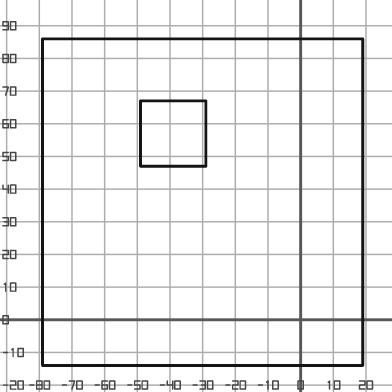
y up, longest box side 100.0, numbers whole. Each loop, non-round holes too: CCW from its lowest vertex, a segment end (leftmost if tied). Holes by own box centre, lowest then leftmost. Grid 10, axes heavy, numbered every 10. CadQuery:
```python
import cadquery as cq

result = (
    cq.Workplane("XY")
    .moveTo(-79.0, -14.0)
    .lineTo(19.0, -14.0)
    .lineTo(19.0, 86.0)
    .lineTo(-79.0, 86.0)
    .close()
    .moveTo(-49.0, 47.0)
    .lineTo(-29.0, 47.0)
    .lineTo(-29.0, 67.0)
    .lineTo(-49.0, 67.0)
    .close()
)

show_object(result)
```